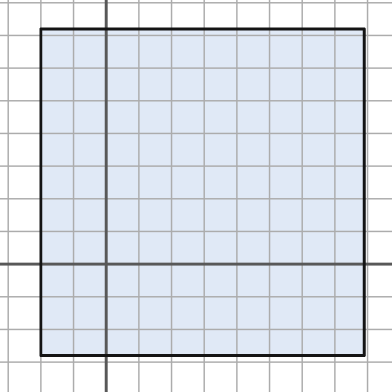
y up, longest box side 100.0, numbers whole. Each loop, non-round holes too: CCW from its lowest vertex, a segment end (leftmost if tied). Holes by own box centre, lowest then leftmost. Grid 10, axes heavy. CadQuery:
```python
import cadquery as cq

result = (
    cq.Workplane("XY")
    .moveTo(-20.0, -28.0)
    .lineTo(79.0, -28.0)
    .lineTo(79.0, 72.0)
    .lineTo(-20.0, 72.0)
    .close()
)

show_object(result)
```